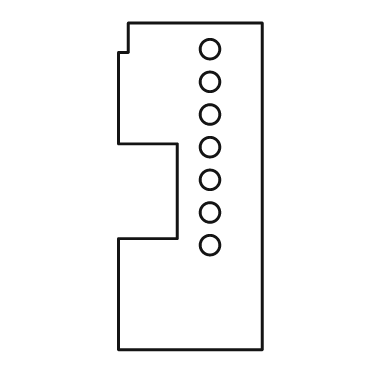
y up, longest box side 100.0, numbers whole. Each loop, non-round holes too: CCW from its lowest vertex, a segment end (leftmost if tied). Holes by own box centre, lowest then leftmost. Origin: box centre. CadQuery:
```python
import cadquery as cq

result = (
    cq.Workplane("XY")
    .moveTo(-22.0, -50.0)
    .lineTo(22.0, -50.0)
    .lineTo(22.0, 50.0)
    .lineTo(-19.0, 50.0)
    .lineTo(-19.0, 41.0)
    .lineTo(-22.0, 41.0)
    .lineTo(-22.0, 13.0)
    .lineTo(-4.0, 13.0)
    .lineTo(-4.0, -16.0)
    .lineTo(-22.0, -16.0)
    .close()
    .moveTo(6.0, -18.0)
    .circle(3.0)
    .moveTo(6.0, -8.0)
    .circle(3.0)
    .moveTo(6.0, 2.0)
    .circle(3.0)
    .moveTo(6.0, 12.0)
    .circle(3.0)
    .moveTo(6.0, 22.0)
    .circle(3.0)
    .moveTo(6.0, 32.0)
    .circle(3.0)
    .moveTo(6.0, 42.0)
    .circle(3.0)
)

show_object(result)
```